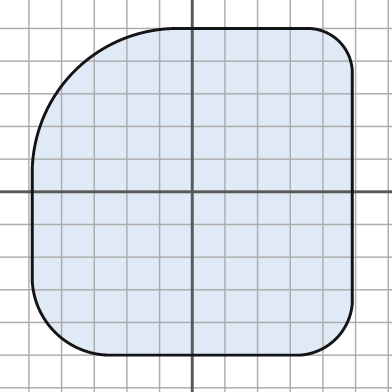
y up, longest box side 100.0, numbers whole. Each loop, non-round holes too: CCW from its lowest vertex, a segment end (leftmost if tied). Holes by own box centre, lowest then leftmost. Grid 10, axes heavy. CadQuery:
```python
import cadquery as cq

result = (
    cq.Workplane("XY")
    .moveTo(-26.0, -50.0)
    .lineTo(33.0, -50.0)
    .threePointArc((44.0, -45.0), (49.0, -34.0))
    .lineTo(49.0, 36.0)
    .threePointArc((45.0, 46.0), (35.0, 50.0))
    .lineTo(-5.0, 50.0)
    .threePointArc((-36.0, 37.0), (-49.0, 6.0))
    .lineTo(-49.0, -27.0)
    .threePointArc((-42.0, -43.0), (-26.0, -50.0))
    .close()
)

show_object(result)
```